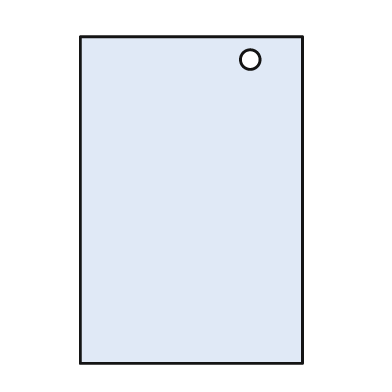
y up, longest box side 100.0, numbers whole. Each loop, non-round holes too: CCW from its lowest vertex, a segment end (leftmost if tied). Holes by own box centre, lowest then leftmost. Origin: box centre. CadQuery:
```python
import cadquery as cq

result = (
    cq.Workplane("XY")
    .moveTo(-34.0, -50.0)
    .lineTo(34.0, -50.0)
    .lineTo(34.0, 50.0)
    .lineTo(-34.0, 50.0)
    .close()
    .moveTo(18.0, 43.0)
    .circle(3.0)
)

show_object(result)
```